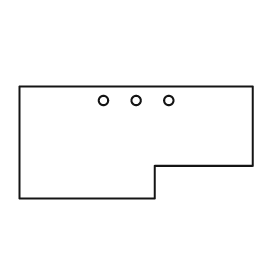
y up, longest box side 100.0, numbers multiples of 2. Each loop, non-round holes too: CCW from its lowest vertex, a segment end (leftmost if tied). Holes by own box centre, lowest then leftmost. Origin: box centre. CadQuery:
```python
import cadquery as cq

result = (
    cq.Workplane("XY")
    .moveTo(-50.0, -24.0)
    .lineTo(8.0, -24.0)
    .lineTo(8.0, -10.0)
    .lineTo(50.0, -10.0)
    .lineTo(50.0, 24.0)
    .lineTo(-50.0, 24.0)
    .close()
    .moveTo(-14.0, 18.0)
    .circle(2.0)
    .moveTo(0.0, 18.0)
    .circle(2.0)
    .moveTo(14.0, 18.0)
    .circle(2.0)
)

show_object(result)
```